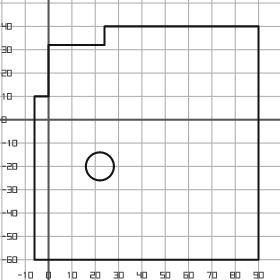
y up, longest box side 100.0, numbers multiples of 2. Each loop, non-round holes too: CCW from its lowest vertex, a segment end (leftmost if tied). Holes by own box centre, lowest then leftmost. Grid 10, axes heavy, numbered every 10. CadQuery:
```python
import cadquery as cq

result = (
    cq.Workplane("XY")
    .moveTo(-6.0, -60.0)
    .lineTo(90.0, -60.0)
    .lineTo(90.0, 40.0)
    .lineTo(24.0, 40.0)
    .lineTo(24.0, 32.0)
    .lineTo(0.0, 32.0)
    .lineTo(0.0, 10.0)
    .lineTo(-6.0, 10.0)
    .close()
    .moveTo(22.0, -20.0)
    .circle(6.0)
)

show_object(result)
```